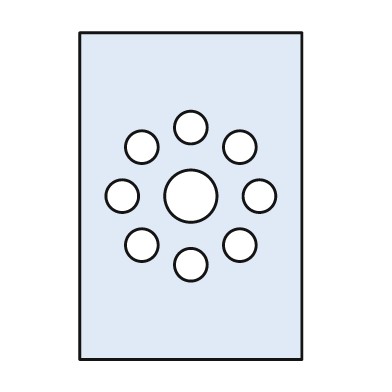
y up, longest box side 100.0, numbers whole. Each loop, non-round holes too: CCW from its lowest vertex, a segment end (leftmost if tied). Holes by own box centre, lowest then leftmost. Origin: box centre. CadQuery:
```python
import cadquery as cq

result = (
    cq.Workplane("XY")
    .moveTo(-34.0, -50.0)
    .lineTo(34.0, -50.0)
    .lineTo(34.0, 50.0)
    .lineTo(-34.0, 50.0)
    .close()
    .moveTo(0.0, -21.0)
    .circle(5.0)
    .moveTo(-15.0, -15.0)
    .circle(5.0)
    .moveTo(15.0, -15.0)
    .circle(5.0)
    .moveTo(-21.0, 0.0)
    .circle(5.0)
    .moveTo(0.0, 0.0)
    .circle(8.0)
    .moveTo(21.0, 0.0)
    .circle(5.0)
    .moveTo(-15.0, 15.0)
    .circle(5.0)
    .moveTo(15.0, 15.0)
    .circle(5.0)
    .moveTo(0.0, 21.0)
    .circle(5.0)
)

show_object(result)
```